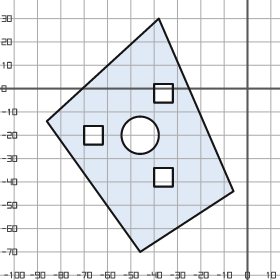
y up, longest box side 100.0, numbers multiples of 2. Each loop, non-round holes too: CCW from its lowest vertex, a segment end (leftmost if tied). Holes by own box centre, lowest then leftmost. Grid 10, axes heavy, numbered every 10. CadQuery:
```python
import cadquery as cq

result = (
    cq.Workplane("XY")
    .moveTo(-46.0, -70.0)
    .lineTo(-6.0, -44.0)
    .lineTo(-38.0, 30.0)
    .lineTo(-86.0, -14.0)
    .close()
    .moveTo(-40.0, -42.0)
    .lineTo(-32.0, -42.0)
    .lineTo(-32.0, -34.0)
    .lineTo(-40.0, -34.0)
    .close()
    .moveTo(-70.0, -24.0)
    .lineTo(-62.0, -24.0)
    .lineTo(-62.0, -16.0)
    .lineTo(-70.0, -16.0)
    .close()
    .moveTo(-46.0, -20.0)
    .circle(8.0)
    .moveTo(-40.0, -6.0)
    .lineTo(-32.0, -6.0)
    .lineTo(-32.0, 2.0)
    .lineTo(-40.0, 2.0)
    .close()
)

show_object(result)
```